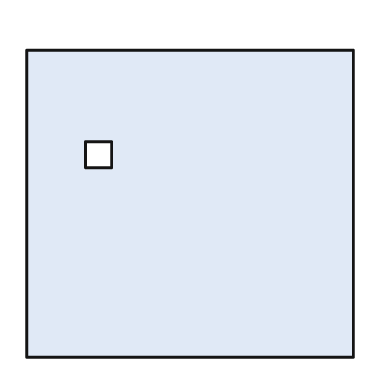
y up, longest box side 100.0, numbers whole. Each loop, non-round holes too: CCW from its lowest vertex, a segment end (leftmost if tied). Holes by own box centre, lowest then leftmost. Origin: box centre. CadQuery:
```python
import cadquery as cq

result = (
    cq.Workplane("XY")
    .moveTo(-50.0, -47.0)
    .lineTo(50.0, -47.0)
    .lineTo(50.0, 47.0)
    .lineTo(-50.0, 47.0)
    .close()
    .moveTo(-32.0, 11.0)
    .lineTo(-24.0, 11.0)
    .lineTo(-24.0, 19.0)
    .lineTo(-32.0, 19.0)
    .close()
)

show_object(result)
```